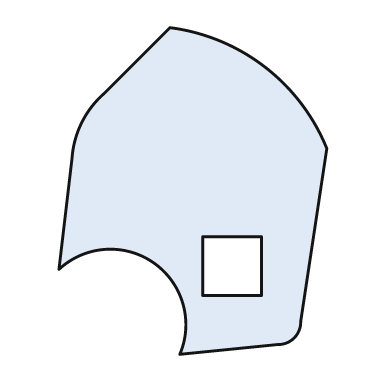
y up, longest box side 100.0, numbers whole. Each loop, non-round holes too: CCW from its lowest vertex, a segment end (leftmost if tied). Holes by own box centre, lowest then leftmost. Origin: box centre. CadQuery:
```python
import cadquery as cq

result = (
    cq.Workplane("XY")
    .moveTo(-4.0, -50.0)
    .lineTo(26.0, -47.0)
    .threePointArc((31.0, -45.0), (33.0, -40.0))
    .lineTo(41.0, 13.0)
    .threePointArc((22.0, 38.0), (-7.0, 50.0))
    .lineTo(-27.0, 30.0)
    .threePointArc((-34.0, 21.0), (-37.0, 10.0))
    .lineTo(-41.0, -24.0)
    .threePointArc((-12.0, -22.0), (-4.0, -50.0))
    .close()
    .moveTo(3.0, -32.0)
    .lineTo(21.0, -32.0)
    .lineTo(21.0, -14.0)
    .lineTo(3.0, -14.0)
    .close()
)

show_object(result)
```